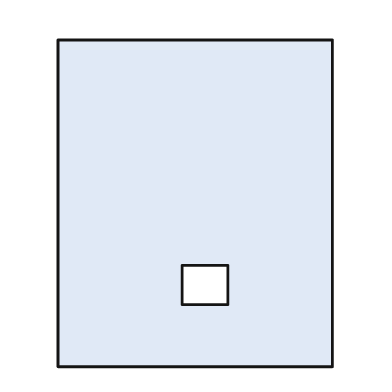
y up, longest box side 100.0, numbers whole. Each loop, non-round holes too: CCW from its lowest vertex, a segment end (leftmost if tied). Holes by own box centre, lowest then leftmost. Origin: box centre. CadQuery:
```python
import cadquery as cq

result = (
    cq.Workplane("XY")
    .moveTo(-42.0, -50.0)
    .lineTo(42.0, -50.0)
    .lineTo(42.0, 50.0)
    .lineTo(-42.0, 50.0)
    .close()
    .moveTo(-4.0, -31.0)
    .lineTo(10.0, -31.0)
    .lineTo(10.0, -19.0)
    .lineTo(-4.0, -19.0)
    .close()
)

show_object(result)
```